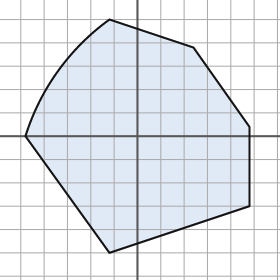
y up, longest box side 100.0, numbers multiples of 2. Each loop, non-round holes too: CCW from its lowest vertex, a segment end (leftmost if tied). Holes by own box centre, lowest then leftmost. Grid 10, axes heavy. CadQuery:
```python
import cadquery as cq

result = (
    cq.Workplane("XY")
    .moveTo(-12.0, -50.0)
    .lineTo(48.0, -30.0)
    .lineTo(48.0, 4.0)
    .lineTo(24.0, 38.0)
    .lineTo(-12.0, 50.0)
    .threePointArc((-34.0, 28.0), (-48.0, 0.0))
    .close()
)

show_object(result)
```